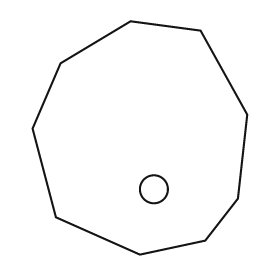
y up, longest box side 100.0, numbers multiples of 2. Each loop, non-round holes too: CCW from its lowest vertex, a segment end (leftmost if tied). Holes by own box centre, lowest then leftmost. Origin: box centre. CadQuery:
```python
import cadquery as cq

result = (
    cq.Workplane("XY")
    .moveTo(0.0, -50.0)
    .lineTo(28.0, -44.0)
    .lineTo(42.0, -26.0)
    .lineTo(46.0, 10.0)
    .lineTo(26.0, 46.0)
    .lineTo(-4.0, 50.0)
    .lineTo(-34.0, 32.0)
    .lineTo(-46.0, 4.0)
    .lineTo(-36.0, -34.0)
    .close()
    .moveTo(6.0, -22.0)
    .circle(6.0)
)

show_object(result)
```